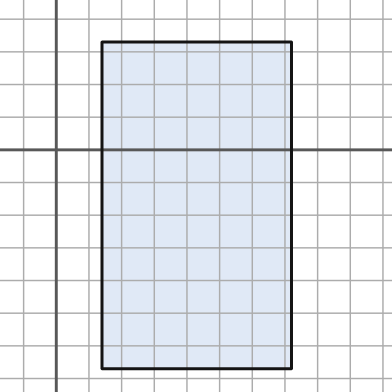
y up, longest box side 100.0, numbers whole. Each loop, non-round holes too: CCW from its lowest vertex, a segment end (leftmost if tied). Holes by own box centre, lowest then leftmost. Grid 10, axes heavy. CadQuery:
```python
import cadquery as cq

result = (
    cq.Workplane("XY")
    .moveTo(14.0, -67.0)
    .lineTo(72.0, -67.0)
    .lineTo(72.0, 33.0)
    .lineTo(14.0, 33.0)
    .close()
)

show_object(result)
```